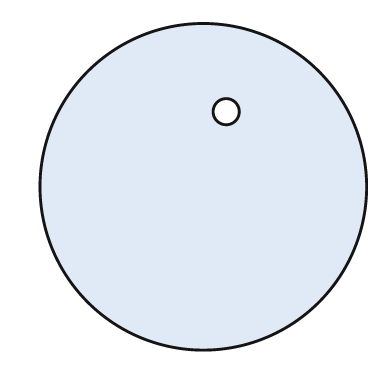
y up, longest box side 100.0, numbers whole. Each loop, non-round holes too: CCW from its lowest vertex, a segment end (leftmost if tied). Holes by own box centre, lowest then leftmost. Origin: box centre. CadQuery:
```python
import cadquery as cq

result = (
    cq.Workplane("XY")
    .moveTo(0.0, 0.0)
    .circle(50.0)
    .moveTo(7.0, 23.0)
    .circle(4.0)
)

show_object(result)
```